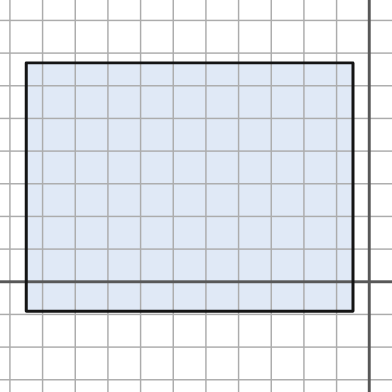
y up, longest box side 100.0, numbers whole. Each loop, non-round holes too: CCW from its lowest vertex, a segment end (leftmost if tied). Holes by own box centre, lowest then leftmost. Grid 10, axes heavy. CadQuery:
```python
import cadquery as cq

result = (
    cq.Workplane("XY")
    .moveTo(-105.0, -9.0)
    .lineTo(-5.0, -9.0)
    .lineTo(-5.0, 67.0)
    .lineTo(-105.0, 67.0)
    .close()
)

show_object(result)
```